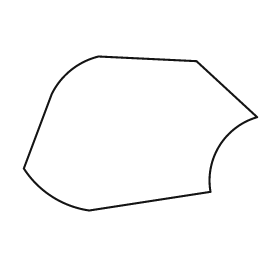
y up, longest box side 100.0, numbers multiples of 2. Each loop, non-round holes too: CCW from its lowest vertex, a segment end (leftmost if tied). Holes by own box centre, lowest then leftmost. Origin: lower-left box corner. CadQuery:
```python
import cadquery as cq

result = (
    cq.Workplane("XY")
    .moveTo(28.0, 0.0)
    .lineTo(80.0, 8.0)
    .threePointArc((84.0, 28.0), (100.0, 40.0))
    .lineTo(74.0, 64.0)
    .lineTo(32.0, 66.0)
    .threePointArc((20.0, 60.0), (12.0, 50.0))
    .lineTo(0.0, 18.0)
    .threePointArc((12.0, 6.0), (28.0, 0.0))
    .close()
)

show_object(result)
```